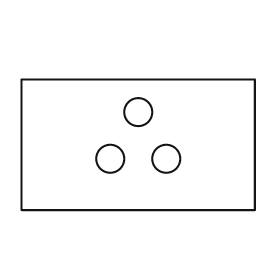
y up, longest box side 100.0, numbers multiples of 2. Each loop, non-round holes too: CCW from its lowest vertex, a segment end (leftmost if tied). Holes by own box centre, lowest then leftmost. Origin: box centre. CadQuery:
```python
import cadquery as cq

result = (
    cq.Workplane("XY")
    .moveTo(-50.0, -28.0)
    .lineTo(50.0, -28.0)
    .lineTo(50.0, 28.0)
    .lineTo(-50.0, 28.0)
    .close()
    .moveTo(-12.0, -6.0)
    .circle(6.0)
    .moveTo(12.0, -6.0)
    .circle(6.0)
    .moveTo(0.0, 14.0)
    .circle(6.0)
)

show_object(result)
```